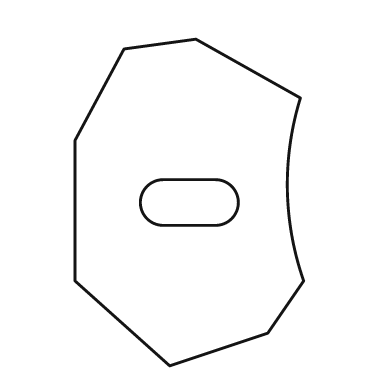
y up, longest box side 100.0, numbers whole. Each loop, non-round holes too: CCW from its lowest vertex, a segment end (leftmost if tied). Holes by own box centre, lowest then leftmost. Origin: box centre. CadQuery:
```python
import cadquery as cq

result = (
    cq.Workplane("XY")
    .moveTo(-6.0, -50.0)
    .lineTo(24.0, -40.0)
    .lineTo(35.0, -24.0)
    .threePointArc((30.0, 4.0), (34.0, 32.0))
    .lineTo(2.0, 50.0)
    .lineTo(-20.0, 47.0)
    .lineTo(-35.0, 19.0)
    .lineTo(-35.0, -24.0)
    .close()
    .moveTo(-8.0, -7.0)
    .lineTo(8.0, -7.0)
    .threePointArc((15.0, 0.0), (8.0, 7.0))
    .lineTo(-8.0, 7.0)
    .threePointArc((-15.0, 0.0), (-8.0, -7.0))
    .close()
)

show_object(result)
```